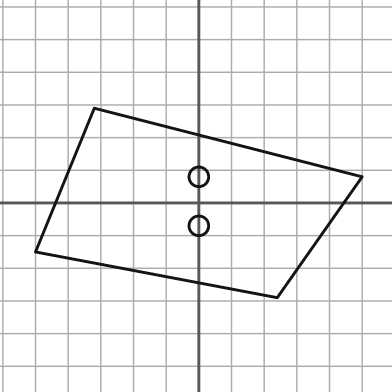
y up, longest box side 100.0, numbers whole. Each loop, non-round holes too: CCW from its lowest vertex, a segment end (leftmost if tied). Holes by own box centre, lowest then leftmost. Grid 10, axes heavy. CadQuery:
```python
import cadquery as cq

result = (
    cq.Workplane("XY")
    .moveTo(24.0, -29.0)
    .lineTo(50.0, 8.0)
    .lineTo(-32.0, 29.0)
    .lineTo(-50.0, -15.0)
    .close()
    .moveTo(0.0, -7.0)
    .circle(3.0)
    .moveTo(0.0, 8.0)
    .circle(3.0)
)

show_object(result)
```